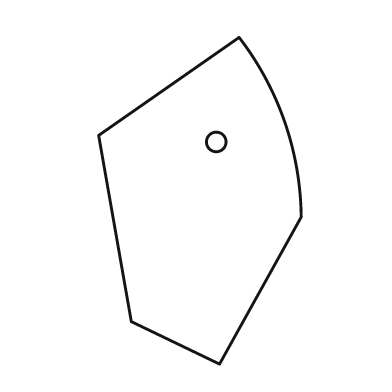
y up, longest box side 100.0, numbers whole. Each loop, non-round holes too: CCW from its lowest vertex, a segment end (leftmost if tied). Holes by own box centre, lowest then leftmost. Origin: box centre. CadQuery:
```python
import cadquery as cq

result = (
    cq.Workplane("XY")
    .moveTo(6.0, -50.0)
    .lineTo(31.0, -5.0)
    .threePointArc((26.0, 24.0), (12.0, 50.0))
    .lineTo(-31.0, 20.0)
    .lineTo(-21.0, -37.0)
    .close()
    .moveTo(5.0, 18.0)
    .circle(3.0)
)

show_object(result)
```